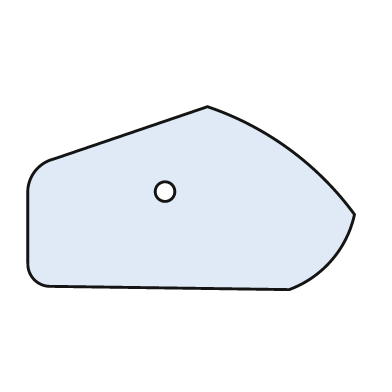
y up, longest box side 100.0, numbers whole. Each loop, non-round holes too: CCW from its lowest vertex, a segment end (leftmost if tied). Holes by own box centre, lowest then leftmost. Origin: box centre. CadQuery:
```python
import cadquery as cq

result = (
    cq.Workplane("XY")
    .moveTo(30.0, -28.0)
    .threePointArc((43.0, -19.0), (50.0, -5.0))
    .threePointArc((30.0, 15.0), (5.0, 28.0))
    .lineTo(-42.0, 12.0)
    .threePointArc((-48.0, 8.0), (-50.0, 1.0))
    .lineTo(-50.0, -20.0)
    .threePointArc((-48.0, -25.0), (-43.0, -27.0))
    .close()
    .moveTo(-8.0, 2.0)
    .circle(3.0)
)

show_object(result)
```